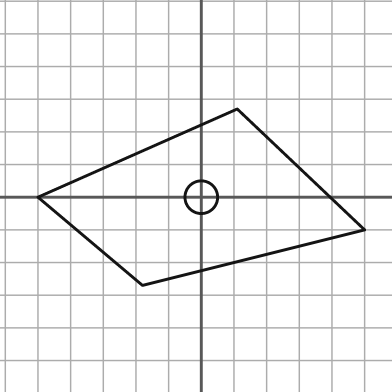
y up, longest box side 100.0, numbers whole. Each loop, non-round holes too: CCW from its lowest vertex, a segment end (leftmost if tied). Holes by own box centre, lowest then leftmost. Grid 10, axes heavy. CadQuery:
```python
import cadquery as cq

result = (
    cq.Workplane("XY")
    .moveTo(-18.0, -27.0)
    .lineTo(50.0, -10.0)
    .lineTo(11.0, 27.0)
    .lineTo(-50.0, 0.0)
    .close()
    .moveTo(0.0, 0.0)
    .circle(5.0)
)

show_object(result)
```